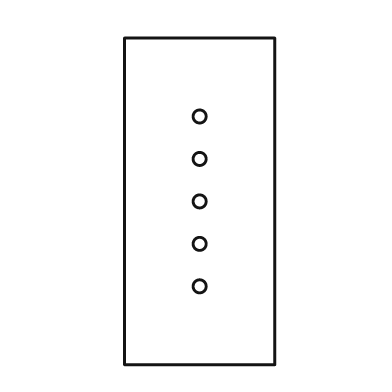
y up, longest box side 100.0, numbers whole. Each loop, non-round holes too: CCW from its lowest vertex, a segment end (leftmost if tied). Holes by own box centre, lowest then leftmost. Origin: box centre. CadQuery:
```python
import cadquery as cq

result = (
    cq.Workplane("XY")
    .moveTo(-23.0, -50.0)
    .lineTo(23.0, -50.0)
    .lineTo(23.0, 50.0)
    .lineTo(-23.0, 50.0)
    .close()
    .moveTo(0.0, -26.0)
    .circle(2.0)
    .moveTo(0.0, -13.0)
    .circle(2.0)
    .moveTo(0.0, 0.0)
    .circle(2.0)
    .moveTo(0.0, 13.0)
    .circle(2.0)
    .moveTo(0.0, 26.0)
    .circle(2.0)
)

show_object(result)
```